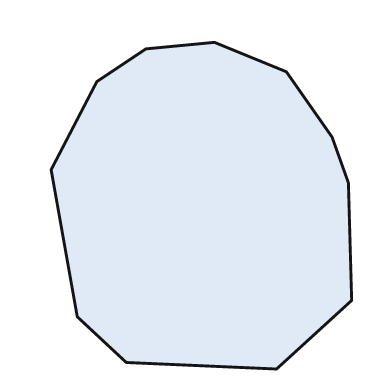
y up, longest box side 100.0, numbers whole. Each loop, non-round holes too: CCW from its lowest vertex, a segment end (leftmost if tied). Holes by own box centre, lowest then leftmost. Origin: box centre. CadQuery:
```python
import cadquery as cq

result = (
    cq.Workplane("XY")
    .moveTo(23.0, -50.0)
    .lineTo(46.0, -29.0)
    .lineTo(45.0, 7.0)
    .lineTo(40.0, 21.0)
    .lineTo(26.0, 41.0)
    .lineTo(4.0, 50.0)
    .lineTo(-17.0, 48.0)
    .lineTo(-32.0, 38.0)
    .lineTo(-46.0, 11.0)
    .lineTo(-38.0, -34.0)
    .lineTo(-23.0, -48.0)
    .close()
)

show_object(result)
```